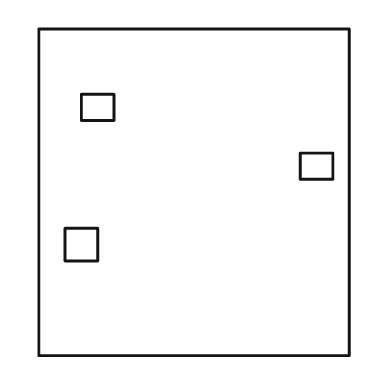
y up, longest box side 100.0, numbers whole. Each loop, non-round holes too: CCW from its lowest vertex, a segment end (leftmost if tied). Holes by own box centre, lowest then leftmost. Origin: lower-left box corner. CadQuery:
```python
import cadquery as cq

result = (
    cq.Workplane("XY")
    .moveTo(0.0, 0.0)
    .lineTo(95.0, 0.0)
    .lineTo(95.0, 100.0)
    .lineTo(0.0, 100.0)
    .close()
    .moveTo(8.0, 29.0)
    .lineTo(18.0, 29.0)
    .lineTo(18.0, 39.0)
    .lineTo(8.0, 39.0)
    .close()
    .moveTo(80.0, 54.0)
    .lineTo(90.0, 54.0)
    .lineTo(90.0, 62.0)
    .lineTo(80.0, 62.0)
    .close()
    .moveTo(13.0, 72.0)
    .lineTo(23.0, 72.0)
    .lineTo(23.0, 80.0)
    .lineTo(13.0, 80.0)
    .close()
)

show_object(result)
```